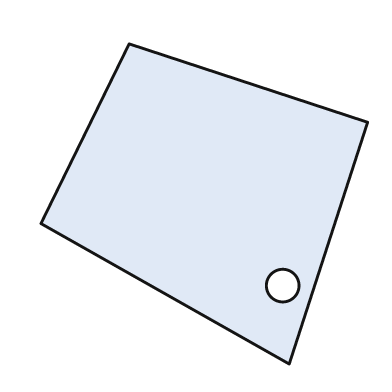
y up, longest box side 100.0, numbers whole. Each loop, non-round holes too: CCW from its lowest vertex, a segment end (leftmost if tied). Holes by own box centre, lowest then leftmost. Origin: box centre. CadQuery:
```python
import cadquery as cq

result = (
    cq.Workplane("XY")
    .moveTo(26.0, -49.0)
    .lineTo(50.0, 25.0)
    .lineTo(-23.0, 49.0)
    .lineTo(-50.0, -6.0)
    .close()
    .moveTo(24.0, -25.0)
    .circle(5.0)
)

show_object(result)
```